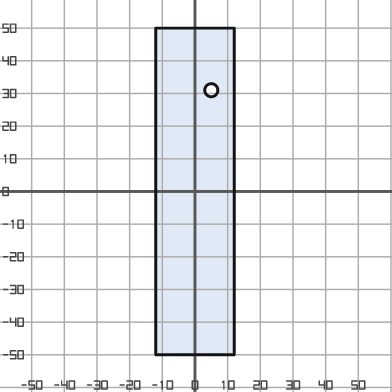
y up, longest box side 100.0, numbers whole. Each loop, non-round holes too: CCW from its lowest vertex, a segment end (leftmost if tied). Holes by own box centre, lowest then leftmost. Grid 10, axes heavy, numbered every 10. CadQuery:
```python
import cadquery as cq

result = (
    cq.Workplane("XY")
    .moveTo(-12.0, -50.0)
    .lineTo(12.0, -50.0)
    .lineTo(12.0, 50.0)
    .lineTo(-12.0, 50.0)
    .close()
    .moveTo(5.0, 31.0)
    .circle(2.0)
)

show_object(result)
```